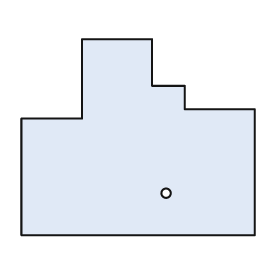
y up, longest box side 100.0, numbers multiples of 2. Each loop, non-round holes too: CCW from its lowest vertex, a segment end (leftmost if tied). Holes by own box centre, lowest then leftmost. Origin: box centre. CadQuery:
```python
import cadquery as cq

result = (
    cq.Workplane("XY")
    .moveTo(-50.0, -42.0)
    .lineTo(50.0, -42.0)
    .lineTo(50.0, 12.0)
    .lineTo(20.0, 12.0)
    .lineTo(20.0, 22.0)
    .lineTo(6.0, 22.0)
    .lineTo(6.0, 42.0)
    .lineTo(-24.0, 42.0)
    .lineTo(-24.0, 8.0)
    .lineTo(-50.0, 8.0)
    .close()
    .moveTo(12.0, -24.0)
    .circle(2.0)
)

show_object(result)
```